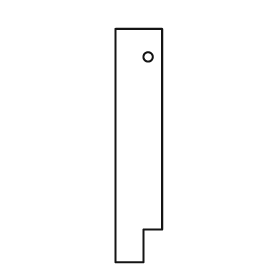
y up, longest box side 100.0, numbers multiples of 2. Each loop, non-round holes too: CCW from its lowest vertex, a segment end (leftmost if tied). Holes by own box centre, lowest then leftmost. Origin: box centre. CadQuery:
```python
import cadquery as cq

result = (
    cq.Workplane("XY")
    .moveTo(-10.0, -50.0)
    .lineTo(2.0, -50.0)
    .lineTo(2.0, -36.0)
    .lineTo(10.0, -36.0)
    .lineTo(10.0, 50.0)
    .lineTo(-10.0, 50.0)
    .close()
    .moveTo(4.0, 38.0)
    .circle(2.0)
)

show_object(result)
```